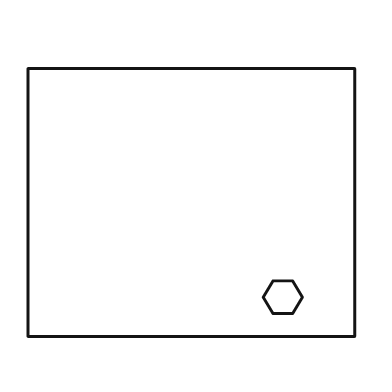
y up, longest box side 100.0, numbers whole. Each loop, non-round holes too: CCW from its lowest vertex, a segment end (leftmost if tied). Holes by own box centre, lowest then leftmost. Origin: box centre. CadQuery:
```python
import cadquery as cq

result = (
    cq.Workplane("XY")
    .moveTo(-50.0, -41.0)
    .lineTo(50.0, -41.0)
    .lineTo(50.0, 41.0)
    .lineTo(-50.0, 41.0)
    .close()
    .moveTo(25.0, -34.0)
    .lineTo(31.0, -34.0)
    .lineTo(34.0, -29.0)
    .lineTo(31.0, -24.0)
    .lineTo(25.0, -24.0)
    .lineTo(22.0, -29.0)
    .close()
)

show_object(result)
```